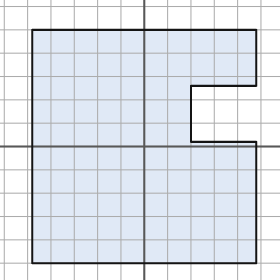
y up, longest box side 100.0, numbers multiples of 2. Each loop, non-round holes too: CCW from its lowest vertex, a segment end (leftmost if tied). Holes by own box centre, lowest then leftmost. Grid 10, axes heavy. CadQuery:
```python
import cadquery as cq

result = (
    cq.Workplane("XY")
    .moveTo(-48.0, -50.0)
    .lineTo(48.0, -50.0)
    .lineTo(48.0, 2.0)
    .lineTo(20.0, 2.0)
    .lineTo(20.0, 26.0)
    .lineTo(48.0, 26.0)
    .lineTo(48.0, 50.0)
    .lineTo(-48.0, 50.0)
    .close()
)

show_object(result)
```